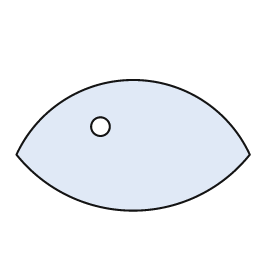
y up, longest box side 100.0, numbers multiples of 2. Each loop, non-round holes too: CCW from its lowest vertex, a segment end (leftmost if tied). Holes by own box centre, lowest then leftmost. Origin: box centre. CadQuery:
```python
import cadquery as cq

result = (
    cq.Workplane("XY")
    .moveTo(-50.0, -4.0)
    .threePointArc((0.0, -28.0), (50.0, -4.0))
    .threePointArc((0.0, 28.0), (-50.0, -4.0))
    .close()
    .moveTo(-14.0, 8.0)
    .circle(4.0)
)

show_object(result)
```